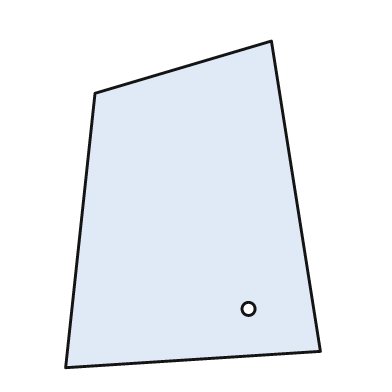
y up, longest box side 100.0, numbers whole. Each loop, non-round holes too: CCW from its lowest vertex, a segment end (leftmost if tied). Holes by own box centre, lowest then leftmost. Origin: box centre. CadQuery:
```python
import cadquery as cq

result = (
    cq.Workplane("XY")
    .moveTo(-39.0, -50.0)
    .lineTo(39.0, -45.0)
    .lineTo(24.0, 50.0)
    .lineTo(-30.0, 34.0)
    .close()
    .moveTo(17.0, -32.0)
    .circle(2.0)
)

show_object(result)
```